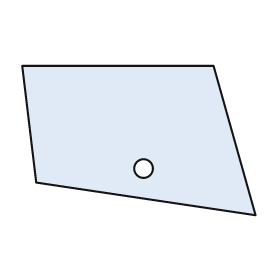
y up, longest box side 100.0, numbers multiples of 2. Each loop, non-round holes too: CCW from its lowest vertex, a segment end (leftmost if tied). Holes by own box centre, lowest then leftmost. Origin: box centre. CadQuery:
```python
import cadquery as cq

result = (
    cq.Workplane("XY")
    .moveTo(50.0, -32.0)
    .lineTo(32.0, 32.0)
    .lineTo(-50.0, 32.0)
    .lineTo(-44.0, -18.0)
    .close()
    .moveTo(2.0, -12.0)
    .circle(4.0)
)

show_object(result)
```